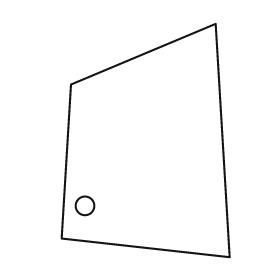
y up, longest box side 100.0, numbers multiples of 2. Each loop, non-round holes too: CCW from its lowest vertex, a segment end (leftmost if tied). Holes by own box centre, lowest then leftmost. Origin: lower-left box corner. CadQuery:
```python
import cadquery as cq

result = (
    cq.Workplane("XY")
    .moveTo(72.0, 0.0)
    .lineTo(66.0, 100.0)
    .lineTo(4.0, 74.0)
    .lineTo(0.0, 8.0)
    .close()
    .moveTo(10.0, 22.0)
    .circle(4.0)
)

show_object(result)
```